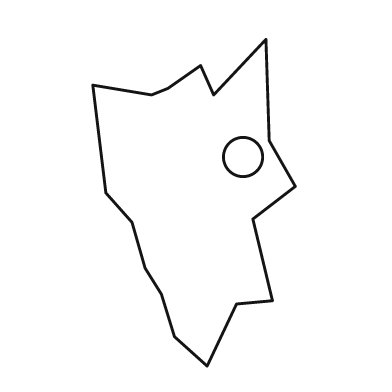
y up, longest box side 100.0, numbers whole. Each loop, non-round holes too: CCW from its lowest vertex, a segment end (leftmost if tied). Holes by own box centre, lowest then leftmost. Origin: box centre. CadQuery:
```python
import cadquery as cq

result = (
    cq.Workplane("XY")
    .moveTo(4.0, -50.0)
    .lineTo(13.0, -31.0)
    .lineTo(24.0, -30.0)
    .lineTo(18.0, -5.0)
    .lineTo(31.0, 5.0)
    .lineTo(23.0, 19.0)
    .lineTo(22.0, 50.0)
    .lineTo(6.0, 33.0)
    .lineTo(2.0, 42.0)
    .lineTo(-8.0, 35.0)
    .lineTo(-13.0, 33.0)
    .lineTo(-31.0, 36.0)
    .lineTo(-27.0, 3.0)
    .lineTo(-19.0, -6.0)
    .lineTo(-15.0, -20.0)
    .lineTo(-10.0, -28.0)
    .lineTo(-6.0, -41.0)
    .close()
    .moveTo(15.0, 14.0)
    .circle(6.0)
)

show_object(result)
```